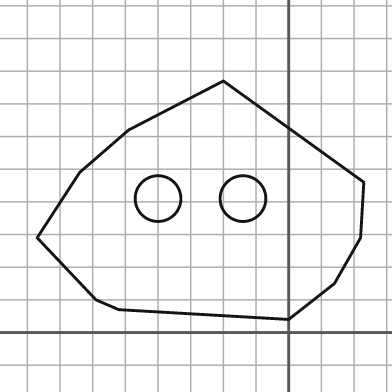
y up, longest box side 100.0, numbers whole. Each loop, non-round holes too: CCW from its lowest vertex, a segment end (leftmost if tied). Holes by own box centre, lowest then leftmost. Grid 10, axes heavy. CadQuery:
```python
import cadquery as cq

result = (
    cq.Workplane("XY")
    .moveTo(0.0, 4.0)
    .lineTo(14.0, 15.0)
    .lineTo(22.0, 29.0)
    .lineTo(23.0, 46.0)
    .lineTo(-20.0, 77.0)
    .lineTo(-49.0, 62.0)
    .lineTo(-64.0, 49.0)
    .lineTo(-77.0, 29.0)
    .lineTo(-59.0, 10.0)
    .lineTo(-52.0, 7.0)
    .close()
    .moveTo(-40.0, 41.0)
    .circle(7.0)
    .moveTo(-14.0, 41.0)
    .circle(7.0)
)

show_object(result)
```